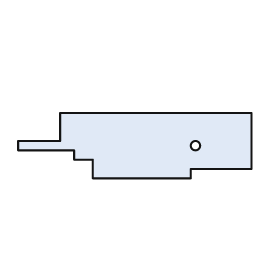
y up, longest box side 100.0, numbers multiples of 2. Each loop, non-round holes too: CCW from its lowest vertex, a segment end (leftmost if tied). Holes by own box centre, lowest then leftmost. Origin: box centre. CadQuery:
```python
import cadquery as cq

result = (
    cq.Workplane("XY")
    .moveTo(-18.0, -14.0)
    .lineTo(24.0, -14.0)
    .lineTo(24.0, -10.0)
    .lineTo(50.0, -10.0)
    .lineTo(50.0, 14.0)
    .lineTo(-32.0, 14.0)
    .lineTo(-32.0, 2.0)
    .lineTo(-50.0, 2.0)
    .lineTo(-50.0, -2.0)
    .lineTo(-26.0, -2.0)
    .lineTo(-26.0, -6.0)
    .lineTo(-18.0, -6.0)
    .close()
    .moveTo(26.0, 0.0)
    .circle(2.0)
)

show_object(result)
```